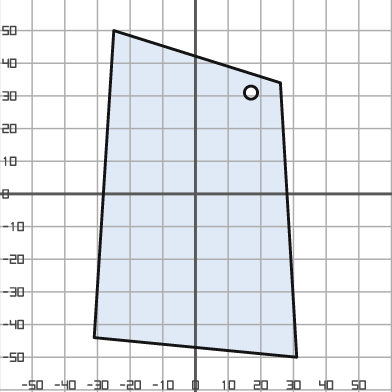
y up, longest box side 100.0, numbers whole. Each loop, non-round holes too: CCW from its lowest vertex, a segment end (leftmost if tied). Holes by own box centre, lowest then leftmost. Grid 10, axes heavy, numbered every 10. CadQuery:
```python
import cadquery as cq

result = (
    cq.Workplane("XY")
    .moveTo(31.0, -50.0)
    .lineTo(26.0, 34.0)
    .lineTo(-25.0, 50.0)
    .lineTo(-31.0, -44.0)
    .close()
    .moveTo(17.0, 31.0)
    .circle(2.0)
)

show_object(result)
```